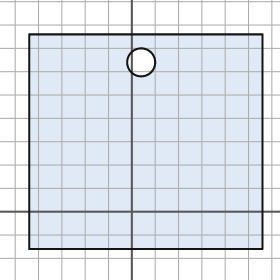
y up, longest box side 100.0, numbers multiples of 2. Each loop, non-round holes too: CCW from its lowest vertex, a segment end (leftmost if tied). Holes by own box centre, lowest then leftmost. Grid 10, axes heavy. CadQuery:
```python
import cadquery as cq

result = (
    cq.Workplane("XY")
    .moveTo(-44.0, -16.0)
    .lineTo(56.0, -16.0)
    .lineTo(56.0, 76.0)
    .lineTo(-44.0, 76.0)
    .close()
    .moveTo(4.0, 64.0)
    .circle(6.0)
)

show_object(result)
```